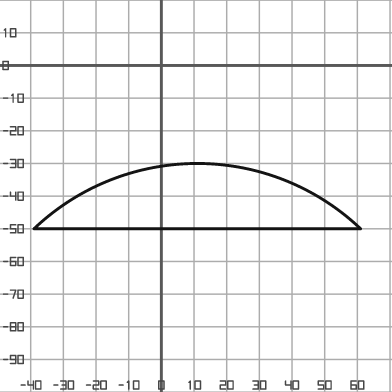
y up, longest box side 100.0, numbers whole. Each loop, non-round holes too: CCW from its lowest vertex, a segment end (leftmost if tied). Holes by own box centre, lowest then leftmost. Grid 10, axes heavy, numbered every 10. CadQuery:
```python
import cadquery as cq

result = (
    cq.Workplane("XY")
    .moveTo(-39.0, -50.0)
    .lineTo(61.0, -50.0)
    .threePointArc((11.0, -30.0), (-39.0, -50.0))
    .close()
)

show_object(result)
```